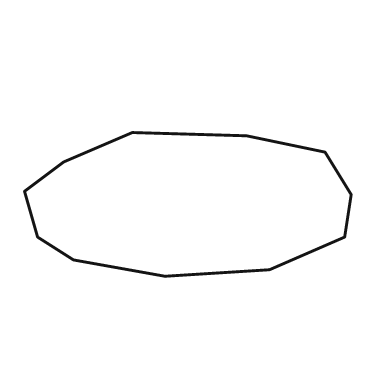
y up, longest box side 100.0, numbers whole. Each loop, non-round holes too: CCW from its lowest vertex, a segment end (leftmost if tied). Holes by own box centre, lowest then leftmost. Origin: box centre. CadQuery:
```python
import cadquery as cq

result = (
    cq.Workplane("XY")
    .moveTo(-7.0, -22.0)
    .lineTo(25.0, -20.0)
    .lineTo(48.0, -10.0)
    .lineTo(50.0, 3.0)
    .lineTo(42.0, 16.0)
    .lineTo(18.0, 21.0)
    .lineTo(-17.0, 22.0)
    .lineTo(-38.0, 13.0)
    .lineTo(-50.0, 4.0)
    .lineTo(-46.0, -10.0)
    .lineTo(-35.0, -17.0)
    .close()
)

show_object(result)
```